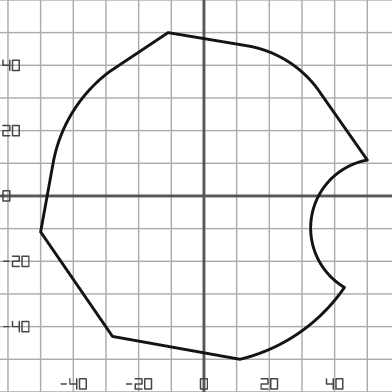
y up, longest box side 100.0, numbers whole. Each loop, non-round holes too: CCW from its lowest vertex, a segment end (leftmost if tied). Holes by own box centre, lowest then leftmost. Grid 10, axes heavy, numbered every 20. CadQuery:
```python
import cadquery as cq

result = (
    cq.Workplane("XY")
    .moveTo(11.0, -50.0)
    .threePointArc((29.0, -42.0), (43.0, -28.0))
    .threePointArc((33.0, -6.0), (50.0, 11.0))
    .lineTo(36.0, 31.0)
    .threePointArc((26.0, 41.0), (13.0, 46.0))
    .lineTo(-11.0, 50.0)
    .lineTo(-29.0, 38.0)
    .threePointArc((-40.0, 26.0), (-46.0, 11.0))
    .lineTo(-50.0, -11.0)
    .lineTo(-28.0, -43.0)
    .close()
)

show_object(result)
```